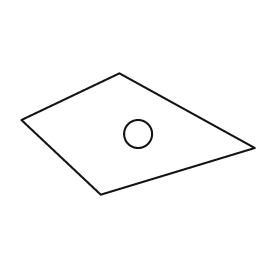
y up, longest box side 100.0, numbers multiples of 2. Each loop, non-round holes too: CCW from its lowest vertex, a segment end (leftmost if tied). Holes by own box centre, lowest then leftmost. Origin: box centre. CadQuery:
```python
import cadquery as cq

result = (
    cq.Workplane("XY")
    .moveTo(-16.0, -26.0)
    .lineTo(50.0, -6.0)
    .lineTo(-8.0, 26.0)
    .lineTo(-50.0, 6.0)
    .close()
    .moveTo(0.0, 0.0)
    .circle(6.0)
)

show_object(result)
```